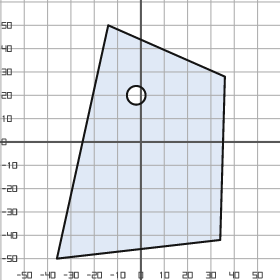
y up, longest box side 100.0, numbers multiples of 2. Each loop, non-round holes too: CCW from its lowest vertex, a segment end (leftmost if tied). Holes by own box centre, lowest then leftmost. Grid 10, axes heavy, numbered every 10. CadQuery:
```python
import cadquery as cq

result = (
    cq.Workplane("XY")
    .moveTo(-36.0, -50.0)
    .lineTo(34.0, -42.0)
    .lineTo(36.0, 28.0)
    .lineTo(-14.0, 50.0)
    .close()
    .moveTo(-2.0, 20.0)
    .circle(4.0)
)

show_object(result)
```